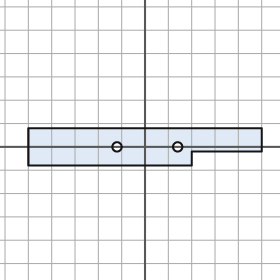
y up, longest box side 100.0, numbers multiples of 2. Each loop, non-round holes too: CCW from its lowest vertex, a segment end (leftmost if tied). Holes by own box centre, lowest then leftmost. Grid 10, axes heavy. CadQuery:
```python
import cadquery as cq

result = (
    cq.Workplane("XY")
    .moveTo(-50.0, -8.0)
    .lineTo(20.0, -8.0)
    .lineTo(20.0, -2.0)
    .lineTo(50.0, -2.0)
    .lineTo(50.0, 8.0)
    .lineTo(-50.0, 8.0)
    .close()
    .moveTo(-12.0, 0.0)
    .circle(2.0)
    .moveTo(14.0, 0.0)
    .circle(2.0)
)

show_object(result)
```